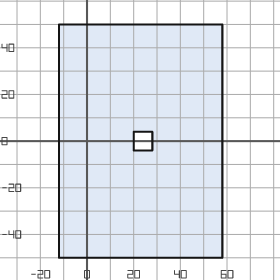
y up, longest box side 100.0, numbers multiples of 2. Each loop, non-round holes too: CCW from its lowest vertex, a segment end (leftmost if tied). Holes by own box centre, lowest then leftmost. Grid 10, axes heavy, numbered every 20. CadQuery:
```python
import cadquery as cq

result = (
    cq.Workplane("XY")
    .moveTo(-12.0, -50.0)
    .lineTo(58.0, -50.0)
    .lineTo(58.0, 50.0)
    .lineTo(-12.0, 50.0)
    .close()
    .moveTo(20.0, -4.0)
    .lineTo(28.0, -4.0)
    .lineTo(28.0, 4.0)
    .lineTo(20.0, 4.0)
    .close()
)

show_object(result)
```